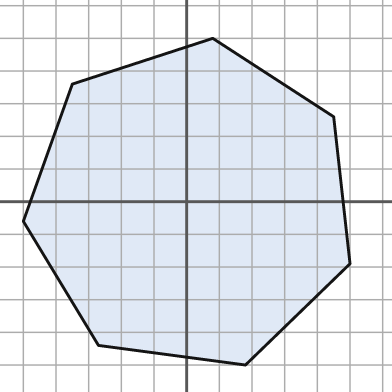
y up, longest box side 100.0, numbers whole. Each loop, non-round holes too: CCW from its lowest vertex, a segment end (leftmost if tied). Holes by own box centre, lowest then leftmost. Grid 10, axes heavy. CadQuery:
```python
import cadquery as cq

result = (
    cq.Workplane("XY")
    .moveTo(18.0, -50.0)
    .lineTo(50.0, -19.0)
    .lineTo(45.0, 26.0)
    .lineTo(8.0, 50.0)
    .lineTo(-35.0, 36.0)
    .lineTo(-50.0, -6.0)
    .lineTo(-27.0, -44.0)
    .close()
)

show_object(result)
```